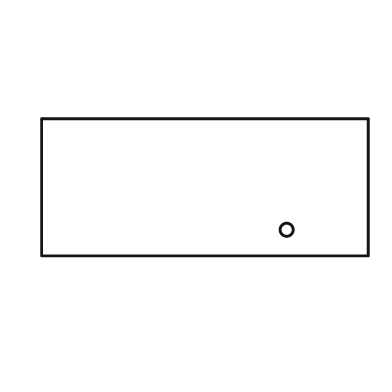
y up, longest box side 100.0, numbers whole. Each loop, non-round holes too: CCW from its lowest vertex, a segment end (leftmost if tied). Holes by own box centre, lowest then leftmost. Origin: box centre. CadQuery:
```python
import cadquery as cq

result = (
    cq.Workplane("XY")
    .moveTo(-50.0, -21.0)
    .lineTo(50.0, -21.0)
    .lineTo(50.0, 21.0)
    .lineTo(-50.0, 21.0)
    .close()
    .moveTo(25.0, -13.0)
    .circle(2.0)
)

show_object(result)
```